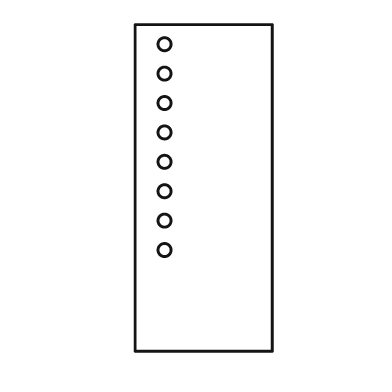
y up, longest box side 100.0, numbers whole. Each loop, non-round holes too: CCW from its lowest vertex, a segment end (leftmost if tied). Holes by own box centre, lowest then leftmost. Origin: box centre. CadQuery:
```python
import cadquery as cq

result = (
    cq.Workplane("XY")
    .moveTo(-21.0, -50.0)
    .lineTo(21.0, -50.0)
    .lineTo(21.0, 50.0)
    .lineTo(-21.0, 50.0)
    .close()
    .moveTo(-12.0, -19.0)
    .circle(2.0)
    .moveTo(-12.0, -10.0)
    .circle(2.0)
    .moveTo(-12.0, -1.0)
    .circle(2.0)
    .moveTo(-12.0, 8.0)
    .circle(2.0)
    .moveTo(-12.0, 17.0)
    .circle(2.0)
    .moveTo(-12.0, 26.0)
    .circle(2.0)
    .moveTo(-12.0, 35.0)
    .circle(2.0)
    .moveTo(-12.0, 44.0)
    .circle(2.0)
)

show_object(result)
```